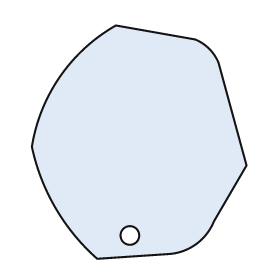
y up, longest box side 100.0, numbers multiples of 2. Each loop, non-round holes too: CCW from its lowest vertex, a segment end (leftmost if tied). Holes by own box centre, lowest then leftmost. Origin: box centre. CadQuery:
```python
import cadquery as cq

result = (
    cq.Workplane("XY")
    .moveTo(-18.0, -50.0)
    .lineTo(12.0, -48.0)
    .threePointArc((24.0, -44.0), (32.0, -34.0))
    .lineTo(46.0, -10.0)
    .lineTo(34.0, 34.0)
    .threePointArc((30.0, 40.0), (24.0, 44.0))
    .lineTo(-10.0, 50.0)
    .threePointArc((-34.0, 28.0), (-46.0, -2.0))
    .threePointArc((-36.0, -28.0), (-18.0, -50.0))
    .close()
    .moveTo(-4.0, -40.0)
    .circle(4.0)
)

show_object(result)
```